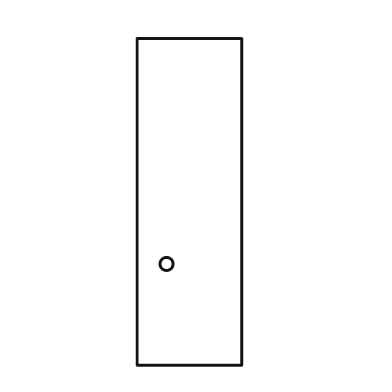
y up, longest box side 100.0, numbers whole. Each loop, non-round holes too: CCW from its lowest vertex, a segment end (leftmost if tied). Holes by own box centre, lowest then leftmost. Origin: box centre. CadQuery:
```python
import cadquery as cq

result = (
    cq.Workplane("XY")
    .moveTo(-16.0, -50.0)
    .lineTo(16.0, -50.0)
    .lineTo(16.0, 50.0)
    .lineTo(-16.0, 50.0)
    .close()
    .moveTo(-7.0, -19.0)
    .circle(2.0)
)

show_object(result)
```